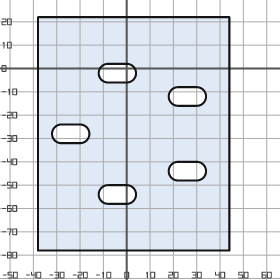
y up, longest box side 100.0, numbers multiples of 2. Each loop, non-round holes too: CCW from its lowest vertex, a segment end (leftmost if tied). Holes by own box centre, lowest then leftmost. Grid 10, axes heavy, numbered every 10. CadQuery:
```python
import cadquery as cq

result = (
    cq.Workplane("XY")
    .moveTo(-38.0, -78.0)
    .lineTo(44.0, -78.0)
    .lineTo(44.0, 22.0)
    .lineTo(-38.0, 22.0)
    .close()
    .moveTo(-8.0, -58.0)
    .lineTo(0.0, -58.0)
    .threePointArc((4.0, -54.0), (0.0, -50.0))
    .lineTo(-8.0, -50.0)
    .threePointArc((-12.0, -54.0), (-8.0, -58.0))
    .close()
    .moveTo(22.0, -48.0)
    .lineTo(30.0, -48.0)
    .threePointArc((34.0, -44.0), (30.0, -40.0))
    .lineTo(22.0, -40.0)
    .threePointArc((18.0, -44.0), (22.0, -48.0))
    .close()
    .moveTo(-28.0, -32.0)
    .lineTo(-20.0, -32.0)
    .threePointArc((-16.0, -28.0), (-20.0, -24.0))
    .lineTo(-28.0, -24.0)
    .threePointArc((-32.0, -28.0), (-28.0, -32.0))
    .close()
    .moveTo(22.0, -16.0)
    .lineTo(30.0, -16.0)
    .threePointArc((34.0, -12.0), (30.0, -8.0))
    .lineTo(22.0, -8.0)
    .threePointArc((18.0, -12.0), (22.0, -16.0))
    .close()
    .moveTo(-8.0, -6.0)
    .lineTo(0.0, -6.0)
    .threePointArc((4.0, -2.0), (0.0, 2.0))
    .lineTo(-8.0, 2.0)
    .threePointArc((-12.0, -2.0), (-8.0, -6.0))
    .close()
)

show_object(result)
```